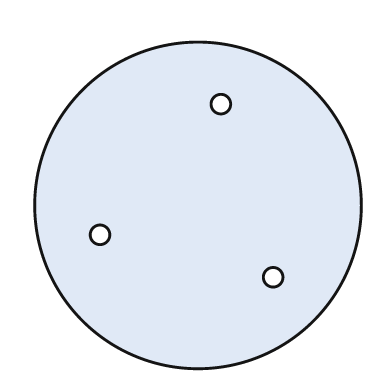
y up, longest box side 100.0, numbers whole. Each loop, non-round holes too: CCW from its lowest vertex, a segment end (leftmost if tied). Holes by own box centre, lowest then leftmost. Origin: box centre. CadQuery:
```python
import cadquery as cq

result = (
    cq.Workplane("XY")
    .moveTo(0.0, 0.0)
    .circle(50.0)
    .moveTo(23.0, -22.0)
    .circle(3.0)
    .moveTo(-30.0, -9.0)
    .circle(3.0)
    .moveTo(7.0, 31.0)
    .circle(3.0)
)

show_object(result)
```